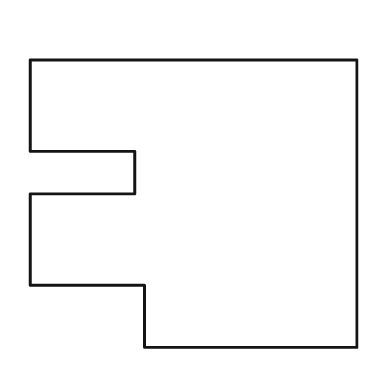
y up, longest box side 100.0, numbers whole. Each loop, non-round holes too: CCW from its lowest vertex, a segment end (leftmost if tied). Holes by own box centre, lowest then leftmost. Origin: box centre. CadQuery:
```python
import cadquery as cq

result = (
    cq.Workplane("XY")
    .moveTo(-15.0, -44.0)
    .lineTo(50.0, -44.0)
    .lineTo(50.0, 44.0)
    .lineTo(-50.0, 44.0)
    .lineTo(-50.0, 16.0)
    .lineTo(-18.0, 16.0)
    .lineTo(-18.0, 3.0)
    .lineTo(-50.0, 3.0)
    .lineTo(-50.0, -25.0)
    .lineTo(-15.0, -25.0)
    .close()
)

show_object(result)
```